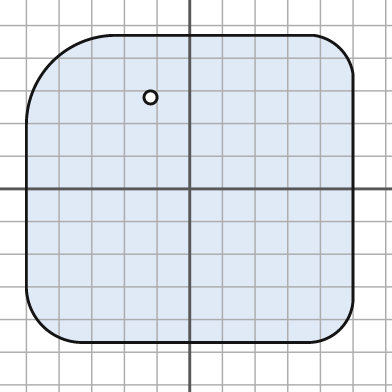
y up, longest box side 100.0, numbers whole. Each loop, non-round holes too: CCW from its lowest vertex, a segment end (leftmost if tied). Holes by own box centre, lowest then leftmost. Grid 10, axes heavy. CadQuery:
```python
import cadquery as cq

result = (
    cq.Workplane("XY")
    .moveTo(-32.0, -47.0)
    .lineTo(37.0, -47.0)
    .threePointArc((46.0, -43.0), (50.0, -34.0))
    .lineTo(50.0, 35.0)
    .threePointArc((46.0, 43.0), (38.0, 47.0))
    .lineTo(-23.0, 47.0)
    .threePointArc((-42.0, 39.0), (-50.0, 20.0))
    .lineTo(-50.0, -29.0)
    .threePointArc((-45.0, -42.0), (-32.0, -47.0))
    .close()
    .moveTo(-12.0, 28.0)
    .circle(2.0)
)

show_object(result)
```